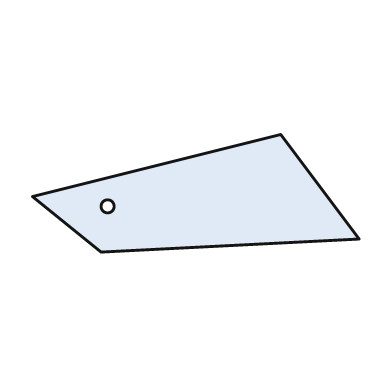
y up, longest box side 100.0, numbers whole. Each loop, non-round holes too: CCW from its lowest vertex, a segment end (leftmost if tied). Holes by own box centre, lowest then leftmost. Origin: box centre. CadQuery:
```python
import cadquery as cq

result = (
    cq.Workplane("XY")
    .moveTo(-29.0, -18.0)
    .lineTo(50.0, -14.0)
    .lineTo(26.0, 18.0)
    .lineTo(-50.0, -1.0)
    .close()
    .moveTo(-27.0, -4.0)
    .circle(2.0)
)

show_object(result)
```